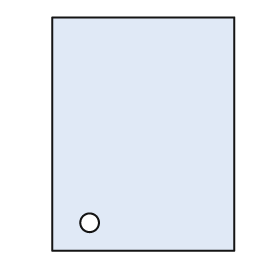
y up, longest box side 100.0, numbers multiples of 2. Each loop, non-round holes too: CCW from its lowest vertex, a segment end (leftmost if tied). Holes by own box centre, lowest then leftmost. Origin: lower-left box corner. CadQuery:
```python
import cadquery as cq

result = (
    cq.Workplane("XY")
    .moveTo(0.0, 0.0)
    .lineTo(78.0, 0.0)
    .lineTo(78.0, 100.0)
    .lineTo(0.0, 100.0)
    .close()
    .moveTo(16.0, 12.0)
    .circle(4.0)
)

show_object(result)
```